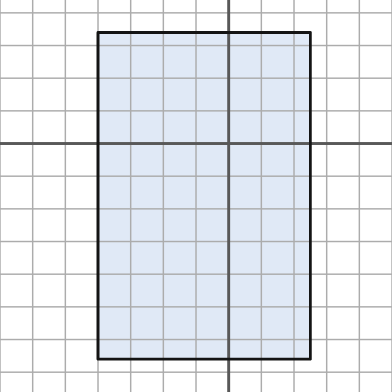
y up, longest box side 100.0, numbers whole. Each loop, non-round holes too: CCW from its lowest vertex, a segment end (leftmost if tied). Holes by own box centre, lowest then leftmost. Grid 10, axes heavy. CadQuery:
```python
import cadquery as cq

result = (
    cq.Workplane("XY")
    .moveTo(-40.0, -66.0)
    .lineTo(25.0, -66.0)
    .lineTo(25.0, 34.0)
    .lineTo(-40.0, 34.0)
    .close()
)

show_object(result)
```